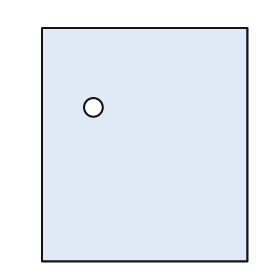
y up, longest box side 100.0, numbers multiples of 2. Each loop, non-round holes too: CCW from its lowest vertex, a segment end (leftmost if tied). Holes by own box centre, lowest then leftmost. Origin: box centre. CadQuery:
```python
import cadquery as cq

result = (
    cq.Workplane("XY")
    .moveTo(-44.0, -50.0)
    .lineTo(44.0, -50.0)
    .lineTo(44.0, 50.0)
    .lineTo(-44.0, 50.0)
    .close()
    .moveTo(-22.0, 16.0)
    .circle(4.0)
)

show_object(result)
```